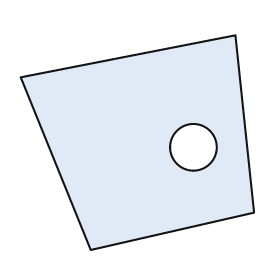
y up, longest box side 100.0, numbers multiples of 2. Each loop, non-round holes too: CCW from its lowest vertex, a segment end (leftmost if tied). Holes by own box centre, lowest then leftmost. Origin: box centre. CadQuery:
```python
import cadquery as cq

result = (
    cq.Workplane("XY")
    .moveTo(-20.0, -46.0)
    .lineTo(50.0, -30.0)
    .lineTo(42.0, 46.0)
    .lineTo(-50.0, 28.0)
    .close()
    .moveTo(24.0, -2.0)
    .circle(10.0)
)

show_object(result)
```